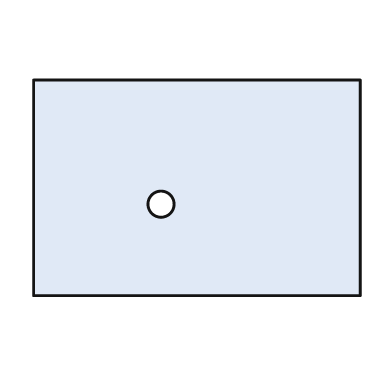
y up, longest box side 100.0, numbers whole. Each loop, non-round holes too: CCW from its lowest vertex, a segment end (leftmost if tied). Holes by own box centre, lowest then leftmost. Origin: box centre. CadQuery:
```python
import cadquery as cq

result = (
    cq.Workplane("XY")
    .moveTo(-50.0, -33.0)
    .lineTo(50.0, -33.0)
    .lineTo(50.0, 33.0)
    .lineTo(-50.0, 33.0)
    .close()
    .moveTo(-11.0, -5.0)
    .circle(4.0)
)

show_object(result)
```